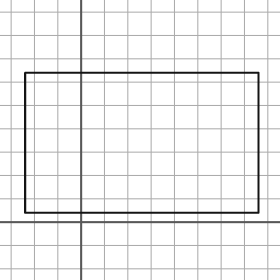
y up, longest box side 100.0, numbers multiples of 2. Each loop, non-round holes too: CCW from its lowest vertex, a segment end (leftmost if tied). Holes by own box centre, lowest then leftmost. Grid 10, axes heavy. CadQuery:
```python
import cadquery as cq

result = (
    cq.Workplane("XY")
    .moveTo(-24.0, 4.0)
    .lineTo(76.0, 4.0)
    .lineTo(76.0, 64.0)
    .lineTo(-24.0, 64.0)
    .close()
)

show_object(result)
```